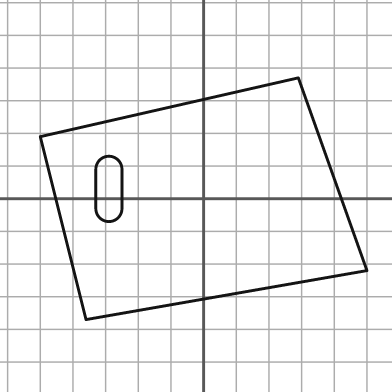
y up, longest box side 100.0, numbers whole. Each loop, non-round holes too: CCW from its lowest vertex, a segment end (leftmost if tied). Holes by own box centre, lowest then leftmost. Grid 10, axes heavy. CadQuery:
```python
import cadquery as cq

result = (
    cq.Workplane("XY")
    .moveTo(-36.0, -37.0)
    .lineTo(50.0, -22.0)
    .lineTo(29.0, 37.0)
    .lineTo(-50.0, 19.0)
    .close()
    .moveTo(-33.0, -3.0)
    .threePointArc((-29.0, -7.0), (-25.0, -3.0))
    .lineTo(-25.0, 9.0)
    .threePointArc((-29.0, 13.0), (-33.0, 9.0))
    .close()
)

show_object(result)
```